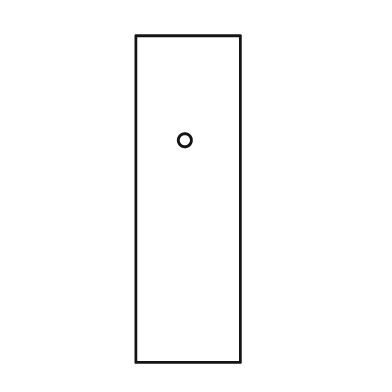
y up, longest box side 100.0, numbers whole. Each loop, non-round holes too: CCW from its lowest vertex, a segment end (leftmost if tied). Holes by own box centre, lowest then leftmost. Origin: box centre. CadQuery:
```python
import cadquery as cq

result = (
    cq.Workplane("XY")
    .moveTo(-16.0, -50.0)
    .lineTo(16.0, -50.0)
    .lineTo(16.0, 50.0)
    .lineTo(-16.0, 50.0)
    .close()
    .moveTo(-1.0, 18.0)
    .circle(2.0)
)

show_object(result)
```